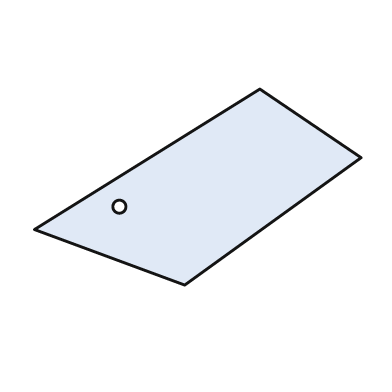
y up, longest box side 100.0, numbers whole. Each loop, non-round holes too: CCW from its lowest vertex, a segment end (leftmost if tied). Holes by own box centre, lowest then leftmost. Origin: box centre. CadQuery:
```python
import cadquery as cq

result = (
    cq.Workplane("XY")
    .moveTo(-4.0, -30.0)
    .lineTo(50.0, 9.0)
    .lineTo(19.0, 30.0)
    .lineTo(-50.0, -13.0)
    .close()
    .moveTo(-24.0, -6.0)
    .circle(2.0)
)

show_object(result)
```